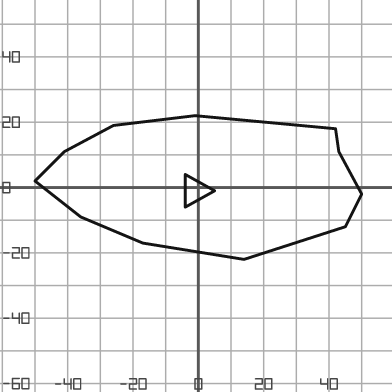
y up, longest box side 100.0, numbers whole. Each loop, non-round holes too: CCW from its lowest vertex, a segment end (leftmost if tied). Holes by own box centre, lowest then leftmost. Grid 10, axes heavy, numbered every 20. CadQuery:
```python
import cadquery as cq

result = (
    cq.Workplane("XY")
    .moveTo(14.0, -22.0)
    .lineTo(45.0, -12.0)
    .lineTo(50.0, -2.0)
    .lineTo(43.0, 11.0)
    .lineTo(42.0, 18.0)
    .lineTo(-1.0, 22.0)
    .lineTo(-26.0, 19.0)
    .lineTo(-41.0, 11.0)
    .lineTo(-50.0, 2.0)
    .lineTo(-36.0, -9.0)
    .lineTo(-17.0, -17.0)
    .close()
    .moveTo(-4.0, -6.0)
    .lineTo(5.0, -1.0)
    .lineTo(-4.0, 4.0)
    .close()
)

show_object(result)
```